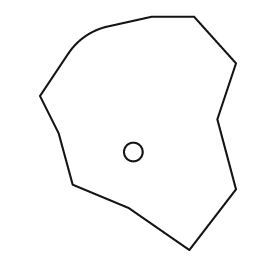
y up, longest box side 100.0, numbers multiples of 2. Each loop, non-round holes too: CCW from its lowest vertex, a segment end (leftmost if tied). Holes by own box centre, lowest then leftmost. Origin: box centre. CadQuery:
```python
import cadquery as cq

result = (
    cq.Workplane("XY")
    .moveTo(22.0, -50.0)
    .lineTo(42.0, -24.0)
    .lineTo(34.0, 6.0)
    .lineTo(42.0, 30.0)
    .lineTo(24.0, 50.0)
    .lineTo(6.0, 50.0)
    .lineTo(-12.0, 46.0)
    .threePointArc((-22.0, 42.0), (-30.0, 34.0))
    .lineTo(-42.0, 16.0)
    .lineTo(-34.0, 0.0)
    .lineTo(-28.0, -22.0)
    .lineTo(-4.0, -32.0)
    .close()
    .moveTo(-2.0, -8.0)
    .circle(4.0)
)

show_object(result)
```